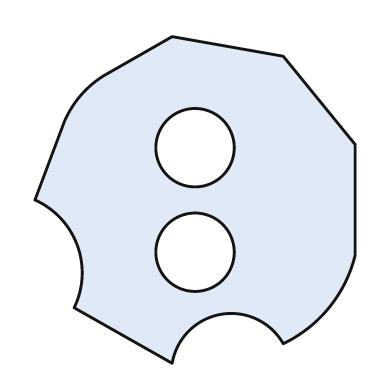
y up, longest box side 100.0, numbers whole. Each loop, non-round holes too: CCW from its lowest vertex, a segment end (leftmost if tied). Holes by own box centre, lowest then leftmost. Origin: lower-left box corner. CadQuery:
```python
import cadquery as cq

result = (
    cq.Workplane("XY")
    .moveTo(42.0, 0.0)
    .threePointArc((57.0, 15.0), (76.0, 6.0))
    .threePointArc((90.0, 17.0), (98.0, 33.0))
    .lineTo(98.0, 67.0)
    .lineTo(76.0, 94.0)
    .lineTo(42.0, 100.0)
    .lineTo(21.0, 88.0)
    .threePointArc((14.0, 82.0), (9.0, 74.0))
    .lineTo(0.0, 50.0)
    .threePointArc((13.0, 36.0), (12.0, 17.0))
    .close()
    .moveTo(49.0, 34.0)
    .circle(12.0)
    .moveTo(49.0, 66.0)
    .circle(12.0)
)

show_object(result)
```